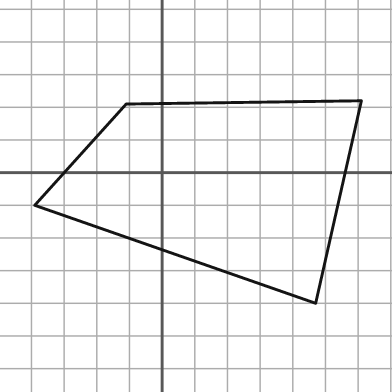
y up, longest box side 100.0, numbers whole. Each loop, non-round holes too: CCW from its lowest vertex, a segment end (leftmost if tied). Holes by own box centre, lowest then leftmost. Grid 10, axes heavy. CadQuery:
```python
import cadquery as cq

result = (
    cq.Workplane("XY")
    .moveTo(47.0, -40.0)
    .lineTo(61.0, 22.0)
    .lineTo(-11.0, 21.0)
    .lineTo(-39.0, -10.0)
    .close()
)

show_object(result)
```